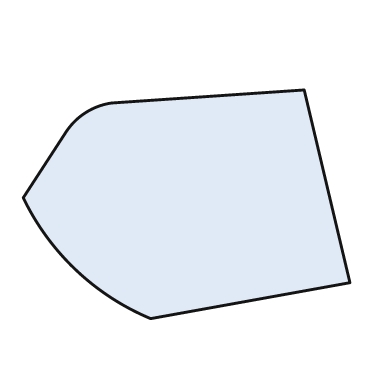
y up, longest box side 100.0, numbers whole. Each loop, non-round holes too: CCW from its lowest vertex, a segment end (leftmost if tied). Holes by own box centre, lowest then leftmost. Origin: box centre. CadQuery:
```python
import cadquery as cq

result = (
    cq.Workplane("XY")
    .moveTo(-11.0, -35.0)
    .lineTo(50.0, -24.0)
    .lineTo(36.0, 35.0)
    .lineTo(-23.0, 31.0)
    .threePointArc((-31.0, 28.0), (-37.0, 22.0))
    .lineTo(-50.0, 2.0)
    .threePointArc((-34.0, -20.0), (-11.0, -35.0))
    .close()
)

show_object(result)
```